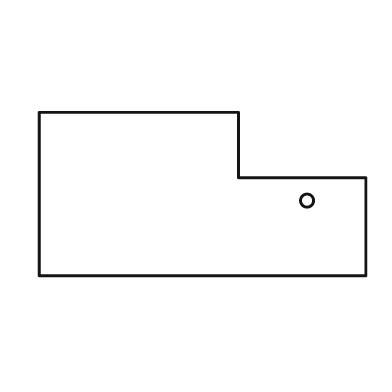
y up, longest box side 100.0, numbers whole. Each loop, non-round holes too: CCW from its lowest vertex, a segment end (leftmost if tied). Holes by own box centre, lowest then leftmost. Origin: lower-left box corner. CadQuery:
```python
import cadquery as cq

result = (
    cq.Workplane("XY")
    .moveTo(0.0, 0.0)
    .lineTo(100.0, 0.0)
    .lineTo(100.0, 30.0)
    .lineTo(61.0, 30.0)
    .lineTo(61.0, 50.0)
    .lineTo(0.0, 50.0)
    .close()
    .moveTo(82.0, 23.0)
    .circle(2.0)
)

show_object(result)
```